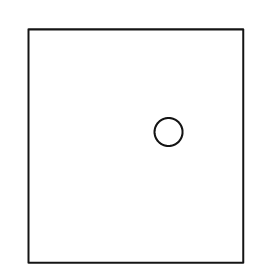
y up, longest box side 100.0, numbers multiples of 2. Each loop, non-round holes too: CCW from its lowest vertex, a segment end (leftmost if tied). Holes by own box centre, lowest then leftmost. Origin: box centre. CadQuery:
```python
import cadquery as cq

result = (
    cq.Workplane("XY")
    .moveTo(-46.0, -50.0)
    .lineTo(46.0, -50.0)
    .lineTo(46.0, 50.0)
    .lineTo(-46.0, 50.0)
    .close()
    .moveTo(14.0, 6.0)
    .circle(6.0)
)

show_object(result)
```